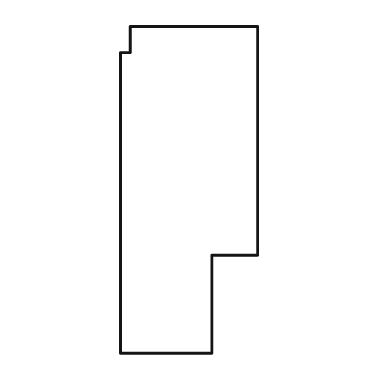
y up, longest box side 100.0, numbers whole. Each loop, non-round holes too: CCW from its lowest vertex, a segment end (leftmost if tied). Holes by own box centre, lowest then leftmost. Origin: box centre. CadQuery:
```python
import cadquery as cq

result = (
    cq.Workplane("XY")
    .moveTo(-21.0, -50.0)
    .lineTo(7.0, -50.0)
    .lineTo(7.0, -20.0)
    .lineTo(21.0, -20.0)
    .lineTo(21.0, 50.0)
    .lineTo(-18.0, 50.0)
    .lineTo(-18.0, 42.0)
    .lineTo(-21.0, 42.0)
    .close()
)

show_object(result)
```